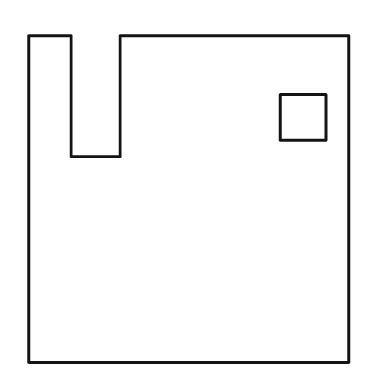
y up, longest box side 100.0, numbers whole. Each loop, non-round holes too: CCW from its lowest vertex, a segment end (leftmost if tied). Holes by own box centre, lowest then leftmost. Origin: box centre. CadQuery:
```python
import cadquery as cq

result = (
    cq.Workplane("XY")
    .moveTo(-49.0, -50.0)
    .lineTo(49.0, -50.0)
    .lineTo(49.0, 50.0)
    .lineTo(-21.0, 50.0)
    .lineTo(-21.0, 13.0)
    .lineTo(-36.0, 13.0)
    .lineTo(-36.0, 50.0)
    .lineTo(-49.0, 50.0)
    .close()
    .moveTo(28.0, 18.0)
    .lineTo(42.0, 18.0)
    .lineTo(42.0, 32.0)
    .lineTo(28.0, 32.0)
    .close()
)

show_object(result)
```